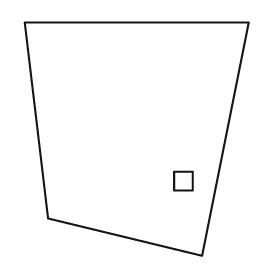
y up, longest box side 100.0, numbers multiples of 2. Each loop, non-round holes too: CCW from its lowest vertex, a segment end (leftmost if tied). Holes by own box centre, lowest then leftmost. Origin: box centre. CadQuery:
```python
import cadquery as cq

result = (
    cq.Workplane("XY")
    .moveTo(28.0, -50.0)
    .lineTo(48.0, 50.0)
    .lineTo(-48.0, 50.0)
    .lineTo(-38.0, -34.0)
    .close()
    .moveTo(16.0, -22.0)
    .lineTo(24.0, -22.0)
    .lineTo(24.0, -14.0)
    .lineTo(16.0, -14.0)
    .close()
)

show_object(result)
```